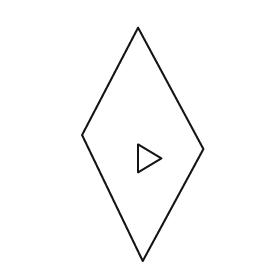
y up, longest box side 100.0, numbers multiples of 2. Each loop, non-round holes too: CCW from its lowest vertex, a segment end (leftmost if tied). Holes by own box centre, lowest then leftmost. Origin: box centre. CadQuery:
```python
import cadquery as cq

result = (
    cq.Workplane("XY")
    .moveTo(0.0, -50.0)
    .lineTo(26.0, -2.0)
    .lineTo(-2.0, 50.0)
    .lineTo(-26.0, 4.0)
    .close()
    .moveTo(-2.0, -12.0)
    .lineTo(8.0, -6.0)
    .lineTo(-2.0, 0.0)
    .close()
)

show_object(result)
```